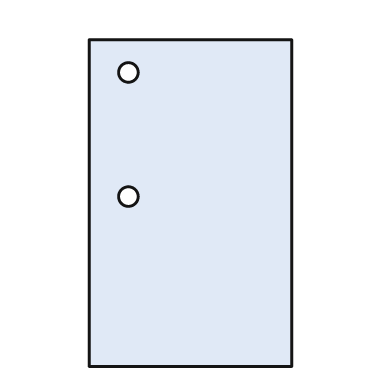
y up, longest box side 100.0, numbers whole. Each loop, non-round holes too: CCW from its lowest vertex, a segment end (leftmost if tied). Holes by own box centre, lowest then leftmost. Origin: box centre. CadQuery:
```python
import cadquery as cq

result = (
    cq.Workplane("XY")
    .moveTo(-31.0, -50.0)
    .lineTo(31.0, -50.0)
    .lineTo(31.0, 50.0)
    .lineTo(-31.0, 50.0)
    .close()
    .moveTo(-19.0, 2.0)
    .circle(3.0)
    .moveTo(-19.0, 40.0)
    .circle(3.0)
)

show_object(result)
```